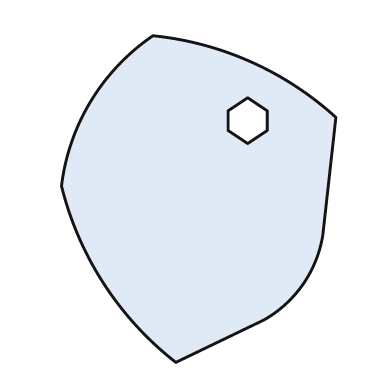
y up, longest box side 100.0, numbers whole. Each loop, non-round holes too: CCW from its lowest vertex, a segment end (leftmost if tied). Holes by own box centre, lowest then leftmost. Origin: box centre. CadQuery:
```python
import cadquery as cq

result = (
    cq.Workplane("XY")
    .moveTo(-7.0, -50.0)
    .lineTo(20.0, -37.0)
    .threePointArc((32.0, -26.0), (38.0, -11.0))
    .lineTo(42.0, 25.0)
    .threePointArc((16.0, 42.0), (-14.0, 50.0))
    .threePointArc((-33.0, 30.0), (-42.0, 4.0))
    .threePointArc((-29.0, -26.0), (-7.0, -50.0))
    .close()
    .moveTo(15.0, 17.0)
    .lineTo(21.0, 21.0)
    .lineTo(21.0, 27.0)
    .lineTo(15.0, 31.0)
    .lineTo(9.0, 27.0)
    .lineTo(9.0, 21.0)
    .close()
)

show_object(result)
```